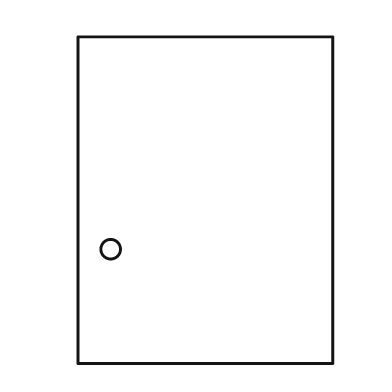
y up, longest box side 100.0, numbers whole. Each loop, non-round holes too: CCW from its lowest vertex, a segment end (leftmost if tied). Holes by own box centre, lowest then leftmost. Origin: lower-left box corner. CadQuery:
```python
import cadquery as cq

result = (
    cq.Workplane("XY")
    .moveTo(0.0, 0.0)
    .lineTo(78.0, 0.0)
    .lineTo(78.0, 100.0)
    .lineTo(0.0, 100.0)
    .close()
    .moveTo(10.0, 35.0)
    .circle(3.0)
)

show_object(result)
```